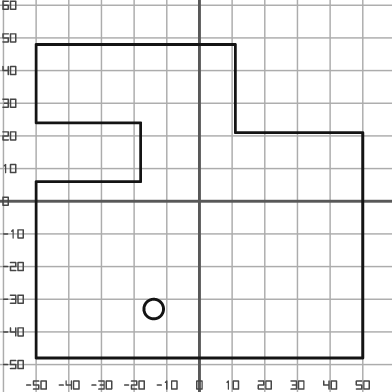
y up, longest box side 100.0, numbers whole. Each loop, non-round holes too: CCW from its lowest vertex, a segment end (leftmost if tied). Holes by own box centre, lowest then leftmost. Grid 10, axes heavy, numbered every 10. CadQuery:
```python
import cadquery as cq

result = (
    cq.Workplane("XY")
    .moveTo(-50.0, -48.0)
    .lineTo(50.0, -48.0)
    .lineTo(50.0, 21.0)
    .lineTo(11.0, 21.0)
    .lineTo(11.0, 48.0)
    .lineTo(-50.0, 48.0)
    .lineTo(-50.0, 24.0)
    .lineTo(-18.0, 24.0)
    .lineTo(-18.0, 6.0)
    .lineTo(-50.0, 6.0)
    .close()
    .moveTo(-14.0, -33.0)
    .circle(3.0)
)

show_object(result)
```